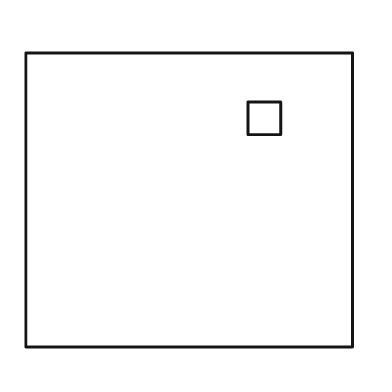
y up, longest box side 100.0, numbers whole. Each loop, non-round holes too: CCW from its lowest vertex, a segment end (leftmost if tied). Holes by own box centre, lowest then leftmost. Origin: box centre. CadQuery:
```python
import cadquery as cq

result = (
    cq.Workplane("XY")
    .moveTo(-50.0, -45.0)
    .lineTo(50.0, -45.0)
    .lineTo(50.0, 45.0)
    .lineTo(-50.0, 45.0)
    .close()
    .moveTo(18.0, 20.0)
    .lineTo(28.0, 20.0)
    .lineTo(28.0, 30.0)
    .lineTo(18.0, 30.0)
    .close()
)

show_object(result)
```